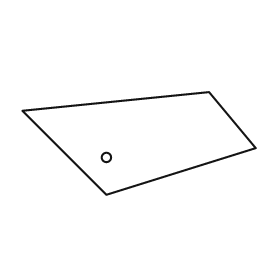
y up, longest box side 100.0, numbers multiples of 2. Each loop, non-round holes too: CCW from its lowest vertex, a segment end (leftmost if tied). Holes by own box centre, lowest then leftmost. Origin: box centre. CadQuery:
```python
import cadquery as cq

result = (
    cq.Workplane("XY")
    .moveTo(-14.0, -22.0)
    .lineTo(50.0, -2.0)
    .lineTo(30.0, 22.0)
    .lineTo(-50.0, 14.0)
    .close()
    .moveTo(-14.0, -6.0)
    .circle(2.0)
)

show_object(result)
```